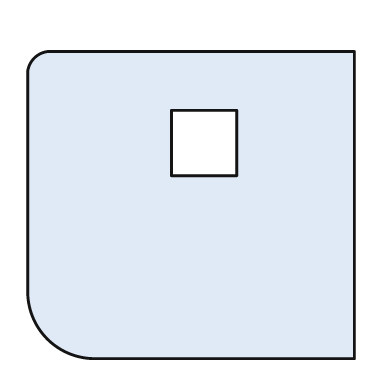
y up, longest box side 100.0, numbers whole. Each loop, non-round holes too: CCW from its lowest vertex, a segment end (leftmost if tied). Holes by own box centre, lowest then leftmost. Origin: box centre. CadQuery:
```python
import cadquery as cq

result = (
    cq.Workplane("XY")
    .moveTo(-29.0, -47.0)
    .lineTo(50.0, -47.0)
    .lineTo(50.0, 47.0)
    .lineTo(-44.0, 47.0)
    .threePointArc((-48.0, 45.0), (-50.0, 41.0))
    .lineTo(-50.0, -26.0)
    .threePointArc((-44.0, -41.0), (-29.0, -47.0))
    .close()
    .moveTo(-6.0, 9.0)
    .lineTo(14.0, 9.0)
    .lineTo(14.0, 29.0)
    .lineTo(-6.0, 29.0)
    .close()
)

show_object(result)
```